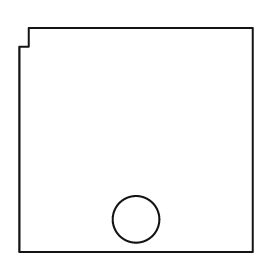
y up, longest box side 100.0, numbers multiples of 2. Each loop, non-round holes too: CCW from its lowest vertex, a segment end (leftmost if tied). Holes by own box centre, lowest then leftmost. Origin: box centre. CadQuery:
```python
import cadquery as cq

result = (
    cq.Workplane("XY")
    .moveTo(-50.0, -48.0)
    .lineTo(50.0, -48.0)
    .lineTo(50.0, 48.0)
    .lineTo(-46.0, 48.0)
    .lineTo(-46.0, 40.0)
    .lineTo(-50.0, 40.0)
    .close()
    .moveTo(0.0, -34.0)
    .circle(10.0)
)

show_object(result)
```